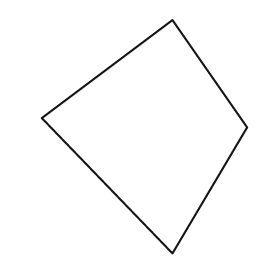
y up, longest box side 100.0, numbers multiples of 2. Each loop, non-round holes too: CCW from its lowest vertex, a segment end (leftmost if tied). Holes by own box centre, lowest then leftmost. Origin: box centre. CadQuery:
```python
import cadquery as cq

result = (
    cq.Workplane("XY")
    .moveTo(12.0, -50.0)
    .lineTo(44.0, 4.0)
    .lineTo(12.0, 50.0)
    .lineTo(-44.0, 8.0)
    .close()
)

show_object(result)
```